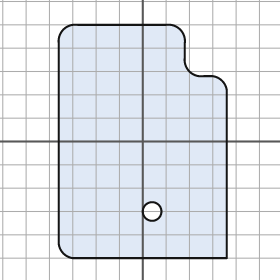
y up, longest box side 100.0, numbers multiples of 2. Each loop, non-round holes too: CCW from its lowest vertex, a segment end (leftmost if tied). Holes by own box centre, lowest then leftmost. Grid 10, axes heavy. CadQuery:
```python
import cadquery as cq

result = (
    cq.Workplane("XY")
    .moveTo(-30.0, -50.0)
    .lineTo(36.0, -50.0)
    .lineTo(36.0, 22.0)
    .threePointArc((34.0, 26.0), (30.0, 28.0))
    .lineTo(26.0, 28.0)
    .threePointArc((20.0, 30.0), (18.0, 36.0))
    .lineTo(18.0, 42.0)
    .threePointArc((16.0, 48.0), (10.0, 50.0))
    .lineTo(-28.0, 50.0)
    .threePointArc((-34.0, 48.0), (-36.0, 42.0))
    .lineTo(-36.0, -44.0)
    .threePointArc((-34.0, -48.0), (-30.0, -50.0))
    .close()
    .moveTo(4.0, -30.0)
    .circle(4.0)
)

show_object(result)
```